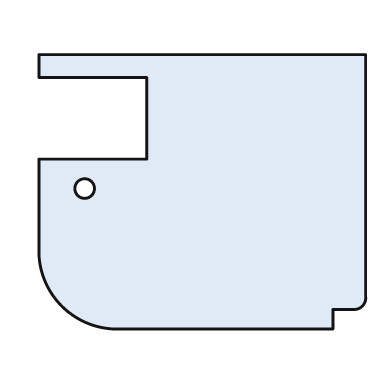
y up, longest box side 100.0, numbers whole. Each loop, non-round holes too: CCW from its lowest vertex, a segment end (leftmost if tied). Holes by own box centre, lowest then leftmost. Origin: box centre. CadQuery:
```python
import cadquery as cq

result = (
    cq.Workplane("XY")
    .moveTo(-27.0, -42.0)
    .lineTo(40.0, -42.0)
    .lineTo(40.0, -36.0)
    .lineTo(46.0, -36.0)
    .threePointArc((49.0, -35.0), (50.0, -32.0))
    .lineTo(50.0, 42.0)
    .lineTo(-50.0, 42.0)
    .lineTo(-50.0, 35.0)
    .lineTo(-17.0, 35.0)
    .lineTo(-17.0, 10.0)
    .lineTo(-50.0, 10.0)
    .lineTo(-50.0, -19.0)
    .threePointArc((-43.0, -35.0), (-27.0, -42.0))
    .close()
    .moveTo(-36.0, 1.0)
    .circle(3.0)
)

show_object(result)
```